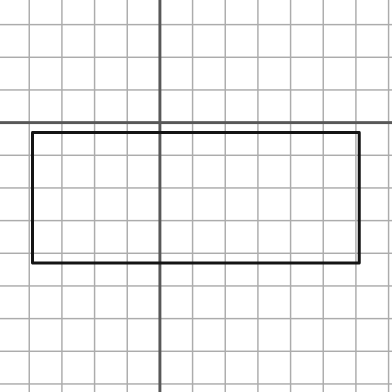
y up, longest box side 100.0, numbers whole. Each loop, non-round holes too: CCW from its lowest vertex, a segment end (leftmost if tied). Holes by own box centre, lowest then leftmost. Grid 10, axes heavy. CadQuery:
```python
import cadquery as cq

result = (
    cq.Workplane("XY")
    .moveTo(-39.0, -43.0)
    .lineTo(61.0, -43.0)
    .lineTo(61.0, -3.0)
    .lineTo(-39.0, -3.0)
    .close()
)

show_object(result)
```